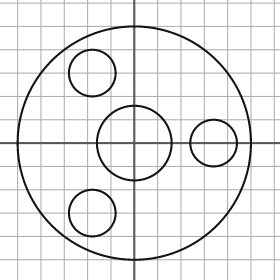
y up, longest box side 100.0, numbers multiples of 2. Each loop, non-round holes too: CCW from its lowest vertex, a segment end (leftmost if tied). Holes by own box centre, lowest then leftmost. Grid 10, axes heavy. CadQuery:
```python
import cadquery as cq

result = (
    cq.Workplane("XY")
    .moveTo(0.0, 0.0)
    .circle(50.0)
    .moveTo(-18.0, -30.0)
    .circle(10.0)
    .moveTo(0.0, 0.0)
    .circle(16.0)
    .moveTo(34.0, 0.0)
    .circle(10.0)
    .moveTo(-18.0, 30.0)
    .circle(10.0)
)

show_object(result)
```